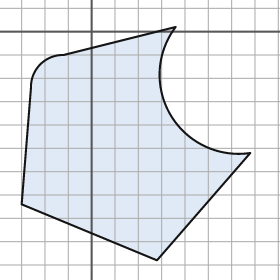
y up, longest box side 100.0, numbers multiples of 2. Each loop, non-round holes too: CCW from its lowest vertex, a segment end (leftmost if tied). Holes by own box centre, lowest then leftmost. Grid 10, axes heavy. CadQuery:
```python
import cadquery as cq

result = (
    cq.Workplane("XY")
    .moveTo(28.0, -98.0)
    .lineTo(68.0, -52.0)
    .threePointArc((34.0, -36.0), (36.0, 2.0))
    .lineTo(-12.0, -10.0)
    .threePointArc((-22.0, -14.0), (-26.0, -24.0))
    .lineTo(-30.0, -74.0)
    .close()
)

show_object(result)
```